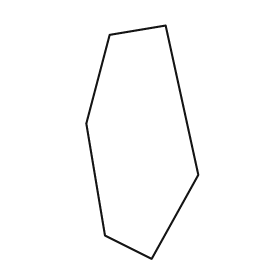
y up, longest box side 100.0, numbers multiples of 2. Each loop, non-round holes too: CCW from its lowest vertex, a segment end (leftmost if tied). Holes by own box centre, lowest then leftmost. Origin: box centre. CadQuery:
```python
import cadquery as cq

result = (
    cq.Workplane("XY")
    .moveTo(4.0, -50.0)
    .lineTo(24.0, -14.0)
    .lineTo(10.0, 50.0)
    .lineTo(-14.0, 46.0)
    .lineTo(-24.0, 8.0)
    .lineTo(-16.0, -40.0)
    .close()
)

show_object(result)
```